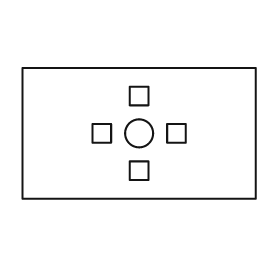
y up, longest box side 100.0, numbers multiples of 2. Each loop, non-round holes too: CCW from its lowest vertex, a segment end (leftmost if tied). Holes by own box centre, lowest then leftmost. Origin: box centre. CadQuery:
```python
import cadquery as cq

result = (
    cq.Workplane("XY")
    .moveTo(-50.0, -28.0)
    .lineTo(50.0, -28.0)
    .lineTo(50.0, 28.0)
    .lineTo(-50.0, 28.0)
    .close()
    .moveTo(-4.0, -20.0)
    .lineTo(4.0, -20.0)
    .lineTo(4.0, -12.0)
    .lineTo(-4.0, -12.0)
    .close()
    .moveTo(-20.0, -4.0)
    .lineTo(-12.0, -4.0)
    .lineTo(-12.0, 4.0)
    .lineTo(-20.0, 4.0)
    .close()
    .moveTo(0.0, 0.0)
    .circle(6.0)
    .moveTo(12.0, -4.0)
    .lineTo(20.0, -4.0)
    .lineTo(20.0, 4.0)
    .lineTo(12.0, 4.0)
    .close()
    .moveTo(-4.0, 12.0)
    .lineTo(4.0, 12.0)
    .lineTo(4.0, 20.0)
    .lineTo(-4.0, 20.0)
    .close()
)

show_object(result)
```